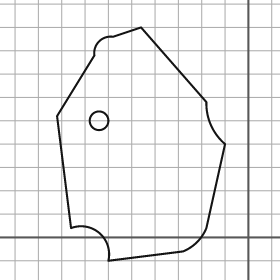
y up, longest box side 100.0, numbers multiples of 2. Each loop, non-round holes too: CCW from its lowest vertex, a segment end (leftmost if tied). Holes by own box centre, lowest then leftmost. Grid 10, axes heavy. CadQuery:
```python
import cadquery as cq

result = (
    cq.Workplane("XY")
    .moveTo(-60.0, -10.0)
    .lineTo(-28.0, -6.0)
    .threePointArc((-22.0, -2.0), (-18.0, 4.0))
    .lineTo(-10.0, 40.0)
    .threePointArc((-16.0, 48.0), (-18.0, 58.0))
    .lineTo(-46.0, 90.0)
    .lineTo(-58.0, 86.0)
    .threePointArc((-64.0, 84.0), (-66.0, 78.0))
    .lineTo(-82.0, 52.0)
    .lineTo(-76.0, 4.0)
    .threePointArc((-64.0, 2.0), (-60.0, -10.0))
    .close()
    .moveTo(-64.0, 50.0)
    .circle(4.0)
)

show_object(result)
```